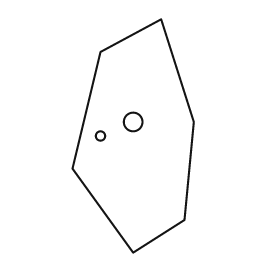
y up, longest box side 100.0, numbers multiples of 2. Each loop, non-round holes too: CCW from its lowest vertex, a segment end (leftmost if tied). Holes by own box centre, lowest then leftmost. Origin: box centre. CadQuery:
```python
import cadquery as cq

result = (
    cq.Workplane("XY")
    .moveTo(0.0, -50.0)
    .lineTo(22.0, -36.0)
    .lineTo(26.0, 6.0)
    .lineTo(12.0, 50.0)
    .lineTo(-14.0, 36.0)
    .lineTo(-26.0, -14.0)
    .close()
    .moveTo(-14.0, 0.0)
    .circle(2.0)
    .moveTo(0.0, 6.0)
    .circle(4.0)
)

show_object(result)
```